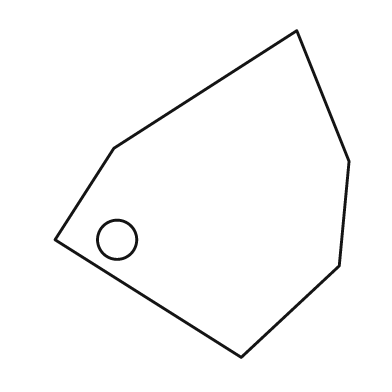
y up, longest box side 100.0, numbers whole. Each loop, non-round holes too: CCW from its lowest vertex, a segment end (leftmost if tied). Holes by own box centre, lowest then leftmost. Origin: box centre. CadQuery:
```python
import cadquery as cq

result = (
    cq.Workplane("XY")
    .moveTo(12.0, -50.0)
    .lineTo(42.0, -22.0)
    .lineTo(45.0, 10.0)
    .lineTo(29.0, 50.0)
    .lineTo(-27.0, 14.0)
    .lineTo(-45.0, -14.0)
    .close()
    .moveTo(-26.0, -14.0)
    .circle(6.0)
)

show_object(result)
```